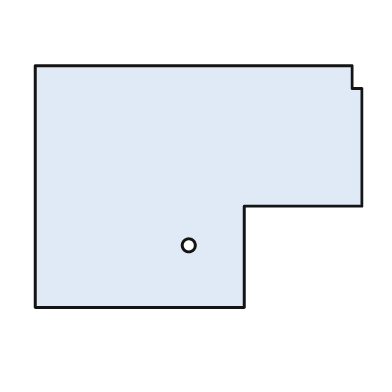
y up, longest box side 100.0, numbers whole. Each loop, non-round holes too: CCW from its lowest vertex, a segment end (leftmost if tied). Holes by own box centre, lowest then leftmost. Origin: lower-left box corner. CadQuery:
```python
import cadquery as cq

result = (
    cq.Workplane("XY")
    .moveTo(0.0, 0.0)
    .lineTo(64.0, 0.0)
    .lineTo(64.0, 31.0)
    .lineTo(100.0, 31.0)
    .lineTo(100.0, 67.0)
    .lineTo(97.0, 67.0)
    .lineTo(97.0, 74.0)
    .lineTo(0.0, 74.0)
    .close()
    .moveTo(47.0, 19.0)
    .circle(2.0)
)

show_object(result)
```